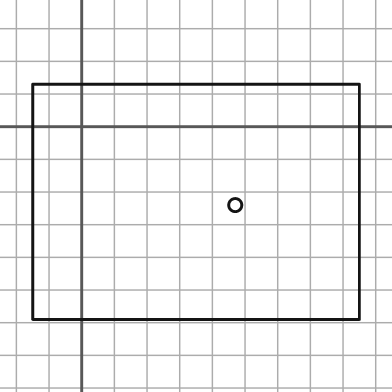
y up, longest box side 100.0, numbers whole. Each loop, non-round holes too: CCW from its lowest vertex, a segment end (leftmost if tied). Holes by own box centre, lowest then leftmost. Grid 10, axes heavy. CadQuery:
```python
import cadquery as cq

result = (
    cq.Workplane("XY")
    .moveTo(-15.0, -59.0)
    .lineTo(85.0, -59.0)
    .lineTo(85.0, 13.0)
    .lineTo(-15.0, 13.0)
    .close()
    .moveTo(47.0, -24.0)
    .circle(2.0)
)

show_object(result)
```